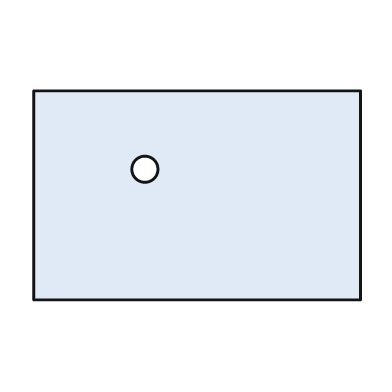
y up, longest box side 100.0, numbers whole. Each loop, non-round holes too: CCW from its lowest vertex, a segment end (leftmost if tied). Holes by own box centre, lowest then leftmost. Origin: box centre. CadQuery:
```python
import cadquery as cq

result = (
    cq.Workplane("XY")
    .moveTo(-50.0, -32.0)
    .lineTo(50.0, -32.0)
    .lineTo(50.0, 32.0)
    .lineTo(-50.0, 32.0)
    .close()
    .moveTo(-16.0, 8.0)
    .circle(4.0)
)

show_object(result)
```